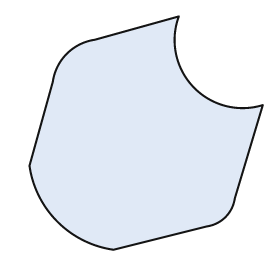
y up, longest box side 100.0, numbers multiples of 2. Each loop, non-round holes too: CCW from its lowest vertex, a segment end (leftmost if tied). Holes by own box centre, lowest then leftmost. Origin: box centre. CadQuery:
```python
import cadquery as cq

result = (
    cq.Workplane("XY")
    .moveTo(-14.0, -50.0)
    .lineTo(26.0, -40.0)
    .threePointArc((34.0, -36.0), (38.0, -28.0))
    .lineTo(50.0, 12.0)
    .threePointArc((20.0, 20.0), (14.0, 50.0))
    .lineTo(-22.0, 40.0)
    .threePointArc((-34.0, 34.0), (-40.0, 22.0))
    .lineTo(-50.0, -14.0)
    .threePointArc((-38.0, -38.0), (-14.0, -50.0))
    .close()
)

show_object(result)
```